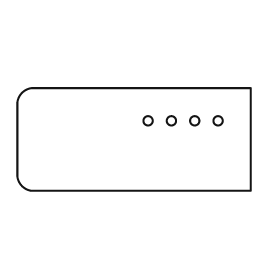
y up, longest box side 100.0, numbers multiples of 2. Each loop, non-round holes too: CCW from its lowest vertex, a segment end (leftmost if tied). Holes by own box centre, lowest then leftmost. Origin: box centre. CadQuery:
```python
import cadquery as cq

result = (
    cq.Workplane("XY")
    .moveTo(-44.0, -22.0)
    .lineTo(50.0, -22.0)
    .lineTo(50.0, 22.0)
    .lineTo(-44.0, 22.0)
    .threePointArc((-48.0, 20.0), (-50.0, 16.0))
    .lineTo(-50.0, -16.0)
    .threePointArc((-48.0, -20.0), (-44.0, -22.0))
    .close()
    .moveTo(6.0, 8.0)
    .circle(2.0)
    .moveTo(16.0, 8.0)
    .circle(2.0)
    .moveTo(26.0, 8.0)
    .circle(2.0)
    .moveTo(36.0, 8.0)
    .circle(2.0)
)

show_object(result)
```